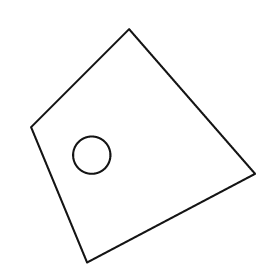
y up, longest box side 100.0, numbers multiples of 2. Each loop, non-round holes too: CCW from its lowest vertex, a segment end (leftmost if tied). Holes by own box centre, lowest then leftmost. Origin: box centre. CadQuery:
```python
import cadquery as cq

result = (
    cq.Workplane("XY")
    .moveTo(-24.0, -50.0)
    .lineTo(48.0, -12.0)
    .lineTo(-6.0, 50.0)
    .lineTo(-48.0, 8.0)
    .close()
    .moveTo(-22.0, -4.0)
    .circle(8.0)
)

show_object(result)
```